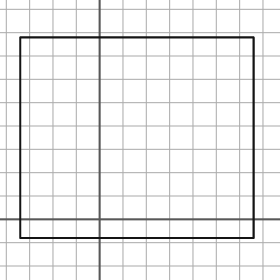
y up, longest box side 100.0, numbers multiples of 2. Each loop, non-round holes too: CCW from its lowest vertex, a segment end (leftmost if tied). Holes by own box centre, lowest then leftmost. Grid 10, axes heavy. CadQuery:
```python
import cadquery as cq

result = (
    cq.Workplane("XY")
    .moveTo(-34.0, -8.0)
    .lineTo(66.0, -8.0)
    .lineTo(66.0, 78.0)
    .lineTo(-34.0, 78.0)
    .close()
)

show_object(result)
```